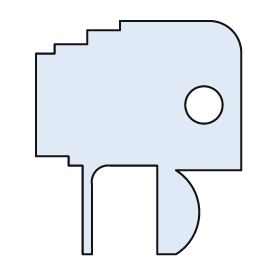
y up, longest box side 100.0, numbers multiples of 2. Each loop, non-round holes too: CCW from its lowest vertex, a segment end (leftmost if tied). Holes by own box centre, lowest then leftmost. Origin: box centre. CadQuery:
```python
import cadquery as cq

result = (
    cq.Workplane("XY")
    .moveTo(-24.0, -50.0)
    .lineTo(-20.0, -50.0)
    .lineTo(-20.0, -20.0)
    .threePointArc((-18.0, -14.0), (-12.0, -12.0))
    .lineTo(8.0, -12.0)
    .lineTo(8.0, -50.0)
    .lineTo(16.0, -50.0)
    .threePointArc((26.0, -32.0), (16.0, -14.0))
    .lineTo(44.0, -14.0)
    .lineTo(44.0, 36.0)
    .threePointArc((40.0, 46.0), (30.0, 50.0))
    .lineTo(-8.0, 50.0)
    .lineTo(-8.0, 46.0)
    .lineTo(-22.0, 46.0)
    .lineTo(-22.0, 40.0)
    .lineTo(-36.0, 40.0)
    .lineTo(-36.0, 36.0)
    .lineTo(-44.0, 36.0)
    .lineTo(-44.0, -8.0)
    .lineTo(-30.0, -8.0)
    .lineTo(-30.0, -12.0)
    .lineTo(-24.0, -12.0)
    .close()
    .moveTo(28.0, 14.0)
    .circle(8.0)
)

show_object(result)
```